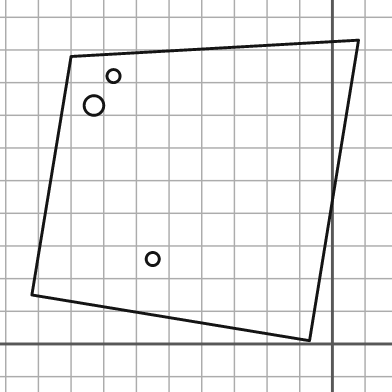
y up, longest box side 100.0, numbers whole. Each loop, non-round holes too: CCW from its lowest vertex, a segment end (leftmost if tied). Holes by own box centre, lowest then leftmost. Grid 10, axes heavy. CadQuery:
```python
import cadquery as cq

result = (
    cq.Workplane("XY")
    .moveTo(-7.0, 1.0)
    .lineTo(8.0, 93.0)
    .lineTo(-80.0, 88.0)
    .lineTo(-92.0, 15.0)
    .close()
    .moveTo(-55.0, 26.0)
    .circle(2.0)
    .moveTo(-73.0, 73.0)
    .circle(3.0)
    .moveTo(-67.0, 82.0)
    .circle(2.0)
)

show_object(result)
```